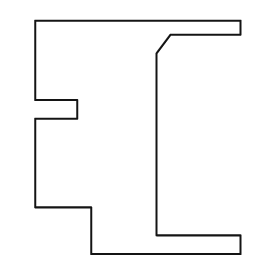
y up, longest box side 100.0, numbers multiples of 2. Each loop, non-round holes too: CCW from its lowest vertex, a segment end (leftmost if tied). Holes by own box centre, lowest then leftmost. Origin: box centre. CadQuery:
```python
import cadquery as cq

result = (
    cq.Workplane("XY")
    .moveTo(-20.0, -50.0)
    .lineTo(44.0, -50.0)
    .lineTo(44.0, -42.0)
    .lineTo(8.0, -42.0)
    .lineTo(8.0, 36.0)
    .lineTo(14.0, 44.0)
    .lineTo(44.0, 44.0)
    .lineTo(44.0, 50.0)
    .lineTo(-44.0, 50.0)
    .lineTo(-44.0, 16.0)
    .lineTo(-26.0, 16.0)
    .lineTo(-26.0, 8.0)
    .lineTo(-44.0, 8.0)
    .lineTo(-44.0, -30.0)
    .lineTo(-20.0, -30.0)
    .close()
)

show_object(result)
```